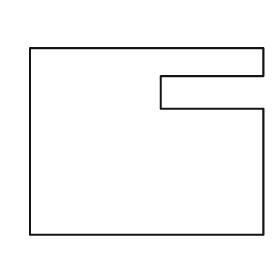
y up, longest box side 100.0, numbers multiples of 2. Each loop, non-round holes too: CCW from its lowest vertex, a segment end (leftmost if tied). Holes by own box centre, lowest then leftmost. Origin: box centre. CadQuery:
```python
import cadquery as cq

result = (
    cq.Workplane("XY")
    .moveTo(-50.0, -40.0)
    .lineTo(50.0, -40.0)
    .lineTo(50.0, 14.0)
    .lineTo(6.0, 14.0)
    .lineTo(6.0, 28.0)
    .lineTo(50.0, 28.0)
    .lineTo(50.0, 40.0)
    .lineTo(-50.0, 40.0)
    .close()
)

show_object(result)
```